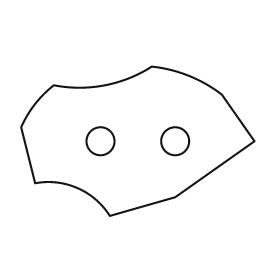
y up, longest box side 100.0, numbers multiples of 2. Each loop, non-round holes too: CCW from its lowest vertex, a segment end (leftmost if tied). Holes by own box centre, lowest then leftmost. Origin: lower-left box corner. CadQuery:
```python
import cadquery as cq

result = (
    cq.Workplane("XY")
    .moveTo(38.0, 0.0)
    .lineTo(66.0, 8.0)
    .lineTo(100.0, 32.0)
    .lineTo(86.0, 52.0)
    .threePointArc((72.0, 60.0), (56.0, 64.0))
    .threePointArc((36.0, 56.0), (14.0, 56.0))
    .threePointArc((6.0, 48.0), (0.0, 38.0))
    .lineTo(6.0, 14.0)
    .threePointArc((24.0, 12.0), (38.0, 0.0))
    .close()
    .moveTo(34.0, 32.0)
    .circle(6.0)
    .moveTo(66.0, 32.0)
    .circle(6.0)
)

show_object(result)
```